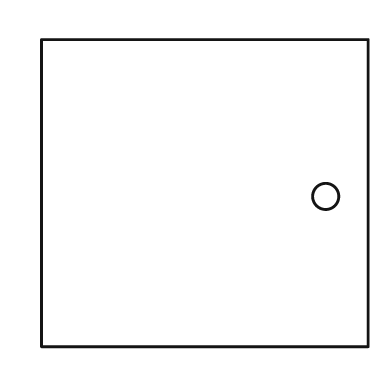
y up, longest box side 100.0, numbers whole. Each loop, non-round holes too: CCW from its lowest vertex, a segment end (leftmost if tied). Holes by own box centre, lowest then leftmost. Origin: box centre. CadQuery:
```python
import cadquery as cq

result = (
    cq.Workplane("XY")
    .moveTo(-50.0, -47.0)
    .lineTo(50.0, -47.0)
    .lineTo(50.0, 47.0)
    .lineTo(-50.0, 47.0)
    .close()
    .moveTo(37.0, -1.0)
    .circle(4.0)
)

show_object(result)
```